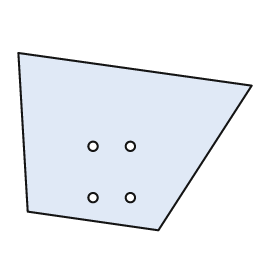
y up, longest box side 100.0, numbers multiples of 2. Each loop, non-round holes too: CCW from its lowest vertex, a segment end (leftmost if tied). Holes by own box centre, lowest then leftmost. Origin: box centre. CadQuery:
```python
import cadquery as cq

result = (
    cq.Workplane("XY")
    .moveTo(10.0, -38.0)
    .lineTo(50.0, 24.0)
    .lineTo(-50.0, 38.0)
    .lineTo(-46.0, -30.0)
    .close()
    .moveTo(-18.0, -24.0)
    .circle(2.0)
    .moveTo(-2.0, -24.0)
    .circle(2.0)
    .moveTo(-18.0, -2.0)
    .circle(2.0)
    .moveTo(-2.0, -2.0)
    .circle(2.0)
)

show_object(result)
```